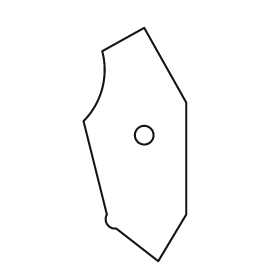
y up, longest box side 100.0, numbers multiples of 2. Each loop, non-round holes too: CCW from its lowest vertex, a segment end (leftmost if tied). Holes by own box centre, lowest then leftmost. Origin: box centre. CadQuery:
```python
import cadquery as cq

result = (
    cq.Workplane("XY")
    .moveTo(10.0, -50.0)
    .lineTo(22.0, -30.0)
    .lineTo(22.0, 18.0)
    .lineTo(4.0, 50.0)
    .lineTo(-14.0, 40.0)
    .threePointArc((-14.0, 24.0), (-22.0, 10.0))
    .lineTo(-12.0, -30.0)
    .threePointArc((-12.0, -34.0), (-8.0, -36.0))
    .close()
    .moveTo(4.0, 4.0)
    .circle(4.0)
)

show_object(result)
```